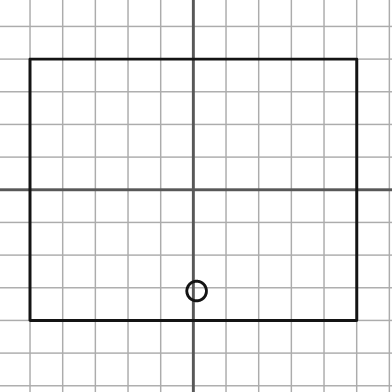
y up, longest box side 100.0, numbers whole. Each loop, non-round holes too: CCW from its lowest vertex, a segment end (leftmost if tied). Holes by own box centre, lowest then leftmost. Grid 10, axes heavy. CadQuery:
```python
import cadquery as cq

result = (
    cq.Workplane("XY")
    .moveTo(-50.0, -40.0)
    .lineTo(50.0, -40.0)
    .lineTo(50.0, 40.0)
    .lineTo(-50.0, 40.0)
    .close()
    .moveTo(1.0, -31.0)
    .circle(3.0)
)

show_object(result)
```